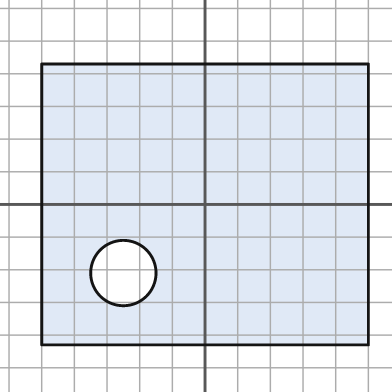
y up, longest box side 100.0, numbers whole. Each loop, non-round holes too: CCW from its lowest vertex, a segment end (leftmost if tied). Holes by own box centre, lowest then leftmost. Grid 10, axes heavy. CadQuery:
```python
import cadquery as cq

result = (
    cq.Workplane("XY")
    .moveTo(-50.0, -43.0)
    .lineTo(50.0, -43.0)
    .lineTo(50.0, 43.0)
    .lineTo(-50.0, 43.0)
    .close()
    .moveTo(-25.0, -21.0)
    .circle(10.0)
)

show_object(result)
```